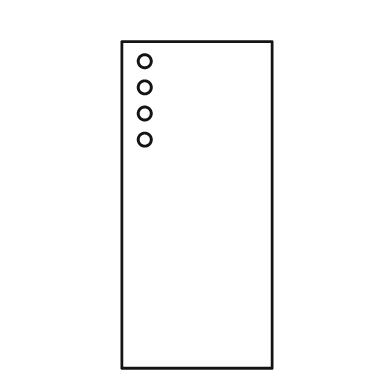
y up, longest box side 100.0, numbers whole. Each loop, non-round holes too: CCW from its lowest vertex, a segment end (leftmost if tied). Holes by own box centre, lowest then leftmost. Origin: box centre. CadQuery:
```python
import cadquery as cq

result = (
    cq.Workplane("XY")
    .moveTo(-23.0, -50.0)
    .lineTo(23.0, -50.0)
    .lineTo(23.0, 50.0)
    .lineTo(-23.0, 50.0)
    .close()
    .moveTo(-16.0, 20.0)
    .circle(2.0)
    .moveTo(-16.0, 28.0)
    .circle(2.0)
    .moveTo(-16.0, 36.0)
    .circle(2.0)
    .moveTo(-16.0, 44.0)
    .circle(2.0)
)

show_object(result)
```